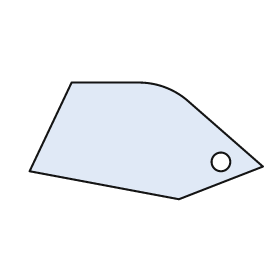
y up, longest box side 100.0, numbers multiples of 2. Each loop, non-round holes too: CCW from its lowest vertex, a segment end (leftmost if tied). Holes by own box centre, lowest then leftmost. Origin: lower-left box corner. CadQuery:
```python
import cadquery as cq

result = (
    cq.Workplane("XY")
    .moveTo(64.0, 0.0)
    .lineTo(100.0, 14.0)
    .lineTo(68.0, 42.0)
    .threePointArc((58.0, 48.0), (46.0, 50.0))
    .lineTo(18.0, 50.0)
    .lineTo(0.0, 12.0)
    .close()
    .moveTo(82.0, 16.0)
    .circle(4.0)
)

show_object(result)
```